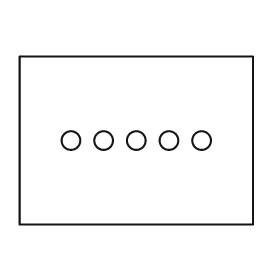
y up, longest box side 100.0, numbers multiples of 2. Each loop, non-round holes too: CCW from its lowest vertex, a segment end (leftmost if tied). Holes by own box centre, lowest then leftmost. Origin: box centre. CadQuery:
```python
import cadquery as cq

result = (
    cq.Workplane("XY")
    .moveTo(-50.0, -36.0)
    .lineTo(50.0, -36.0)
    .lineTo(50.0, 36.0)
    .lineTo(-50.0, 36.0)
    .close()
    .moveTo(-28.0, 0.0)
    .circle(4.0)
    .moveTo(-14.0, 0.0)
    .circle(4.0)
    .moveTo(0.0, 0.0)
    .circle(4.0)
    .moveTo(14.0, 0.0)
    .circle(4.0)
    .moveTo(28.0, 0.0)
    .circle(4.0)
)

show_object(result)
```